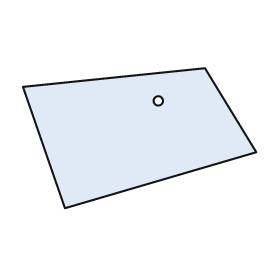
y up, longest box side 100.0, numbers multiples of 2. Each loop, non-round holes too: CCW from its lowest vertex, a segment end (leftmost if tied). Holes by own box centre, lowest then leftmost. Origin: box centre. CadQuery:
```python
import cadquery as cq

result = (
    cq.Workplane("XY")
    .moveTo(-32.0, -30.0)
    .lineTo(50.0, -6.0)
    .lineTo(28.0, 30.0)
    .lineTo(-50.0, 22.0)
    .close()
    .moveTo(8.0, 16.0)
    .circle(2.0)
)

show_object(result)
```